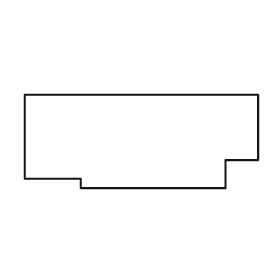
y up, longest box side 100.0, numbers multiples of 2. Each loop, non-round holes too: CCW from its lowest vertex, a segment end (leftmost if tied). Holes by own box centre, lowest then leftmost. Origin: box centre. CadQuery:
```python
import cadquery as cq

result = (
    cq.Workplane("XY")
    .moveTo(-26.0, -20.0)
    .lineTo(36.0, -20.0)
    .lineTo(36.0, -8.0)
    .lineTo(50.0, -8.0)
    .lineTo(50.0, 20.0)
    .lineTo(-50.0, 20.0)
    .lineTo(-50.0, -16.0)
    .lineTo(-26.0, -16.0)
    .close()
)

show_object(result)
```